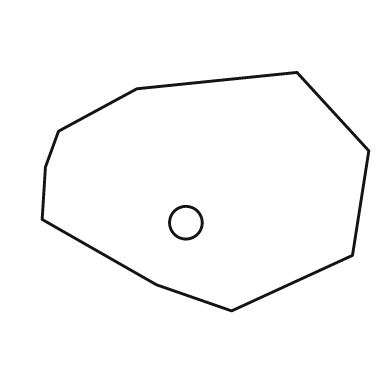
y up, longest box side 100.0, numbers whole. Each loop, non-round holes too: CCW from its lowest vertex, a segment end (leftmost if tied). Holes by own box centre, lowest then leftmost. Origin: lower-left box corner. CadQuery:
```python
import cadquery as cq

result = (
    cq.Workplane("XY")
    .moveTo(58.0, 0.0)
    .lineTo(95.0, 17.0)
    .lineTo(100.0, 49.0)
    .lineTo(78.0, 73.0)
    .lineTo(29.0, 68.0)
    .lineTo(5.0, 55.0)
    .lineTo(1.0, 44.0)
    .lineTo(0.0, 28.0)
    .lineTo(35.0, 8.0)
    .close()
    .moveTo(44.0, 27.0)
    .circle(5.0)
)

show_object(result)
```